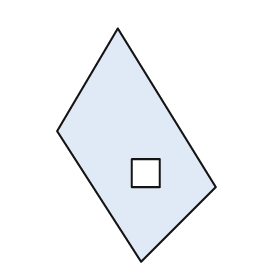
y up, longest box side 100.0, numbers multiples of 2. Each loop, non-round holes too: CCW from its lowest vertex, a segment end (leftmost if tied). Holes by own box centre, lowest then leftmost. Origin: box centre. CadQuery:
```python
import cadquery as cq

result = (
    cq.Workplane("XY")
    .moveTo(2.0, -50.0)
    .lineTo(34.0, -18.0)
    .lineTo(-8.0, 50.0)
    .lineTo(-34.0, 6.0)
    .close()
    .moveTo(-2.0, -18.0)
    .lineTo(10.0, -18.0)
    .lineTo(10.0, -6.0)
    .lineTo(-2.0, -6.0)
    .close()
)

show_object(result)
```